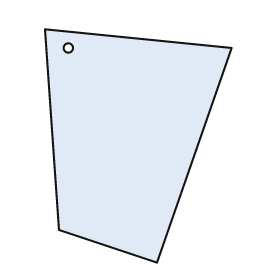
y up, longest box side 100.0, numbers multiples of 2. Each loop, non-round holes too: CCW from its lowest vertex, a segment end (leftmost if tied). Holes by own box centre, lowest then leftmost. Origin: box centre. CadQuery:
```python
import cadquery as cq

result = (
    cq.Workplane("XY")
    .moveTo(8.0, -50.0)
    .lineTo(40.0, 42.0)
    .lineTo(-40.0, 50.0)
    .lineTo(-34.0, -36.0)
    .close()
    .moveTo(-30.0, 42.0)
    .circle(2.0)
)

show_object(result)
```